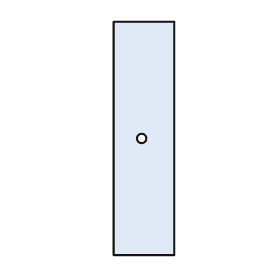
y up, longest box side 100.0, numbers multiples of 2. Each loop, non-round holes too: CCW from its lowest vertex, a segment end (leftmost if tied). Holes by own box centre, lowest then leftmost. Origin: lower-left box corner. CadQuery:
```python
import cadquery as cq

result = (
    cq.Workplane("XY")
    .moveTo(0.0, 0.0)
    .lineTo(26.0, 0.0)
    .lineTo(26.0, 100.0)
    .lineTo(0.0, 100.0)
    .close()
    .moveTo(12.0, 50.0)
    .circle(2.0)
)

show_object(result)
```